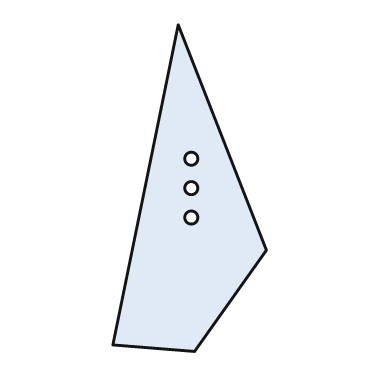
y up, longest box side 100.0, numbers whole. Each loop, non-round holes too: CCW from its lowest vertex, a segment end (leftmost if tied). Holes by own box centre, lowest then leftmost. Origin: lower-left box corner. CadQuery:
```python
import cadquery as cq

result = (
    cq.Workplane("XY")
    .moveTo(25.0, 0.0)
    .lineTo(47.0, 31.0)
    .lineTo(20.0, 100.0)
    .lineTo(0.0, 2.0)
    .close()
    .moveTo(24.0, 41.0)
    .circle(2.0)
    .moveTo(24.0, 50.0)
    .circle(2.0)
    .moveTo(24.0, 59.0)
    .circle(2.0)
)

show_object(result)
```